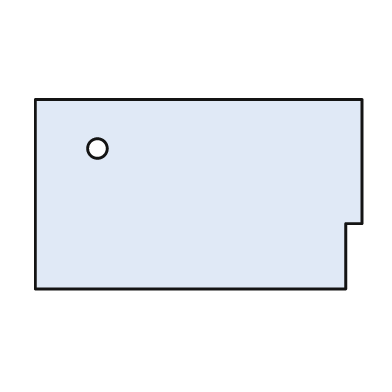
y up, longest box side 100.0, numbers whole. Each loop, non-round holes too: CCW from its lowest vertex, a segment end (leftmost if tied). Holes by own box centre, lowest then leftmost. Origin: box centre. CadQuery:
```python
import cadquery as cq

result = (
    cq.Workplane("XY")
    .moveTo(-50.0, -29.0)
    .lineTo(45.0, -29.0)
    .lineTo(45.0, -9.0)
    .lineTo(50.0, -9.0)
    .lineTo(50.0, 29.0)
    .lineTo(-50.0, 29.0)
    .close()
    .moveTo(-31.0, 14.0)
    .circle(3.0)
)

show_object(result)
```